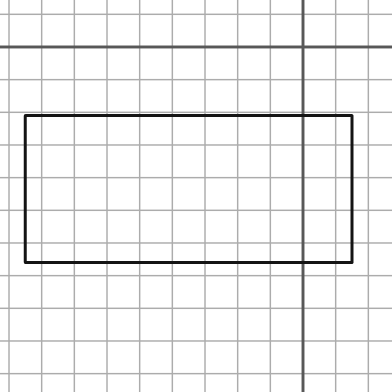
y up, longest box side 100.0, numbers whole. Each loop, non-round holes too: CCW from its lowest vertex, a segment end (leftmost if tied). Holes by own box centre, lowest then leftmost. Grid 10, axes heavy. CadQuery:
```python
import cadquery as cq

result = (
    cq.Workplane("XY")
    .moveTo(-85.0, -66.0)
    .lineTo(15.0, -66.0)
    .lineTo(15.0, -21.0)
    .lineTo(-85.0, -21.0)
    .close()
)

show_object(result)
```